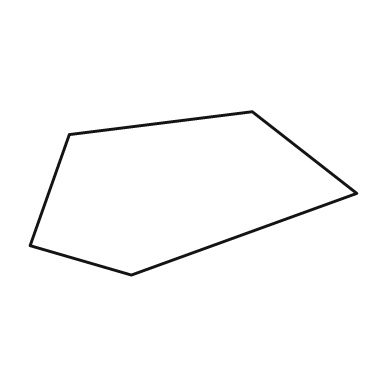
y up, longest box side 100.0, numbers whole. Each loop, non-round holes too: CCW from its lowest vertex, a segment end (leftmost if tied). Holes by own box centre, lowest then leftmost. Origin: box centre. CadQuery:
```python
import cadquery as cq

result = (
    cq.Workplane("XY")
    .moveTo(-19.0, -25.0)
    .lineTo(50.0, 0.0)
    .lineTo(18.0, 25.0)
    .lineTo(-38.0, 18.0)
    .lineTo(-50.0, -16.0)
    .close()
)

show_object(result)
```